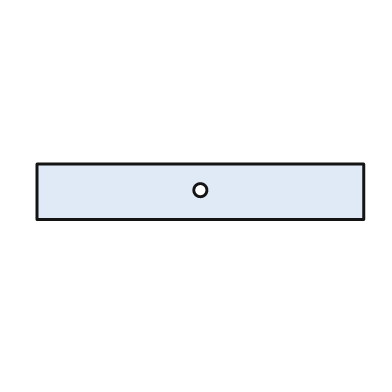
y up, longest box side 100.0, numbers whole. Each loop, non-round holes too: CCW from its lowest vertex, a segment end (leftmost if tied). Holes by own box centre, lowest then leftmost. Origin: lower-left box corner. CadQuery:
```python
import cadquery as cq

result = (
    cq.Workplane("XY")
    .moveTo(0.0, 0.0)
    .lineTo(100.0, 0.0)
    .lineTo(100.0, 17.0)
    .lineTo(0.0, 17.0)
    .close()
    .moveTo(50.0, 9.0)
    .circle(2.0)
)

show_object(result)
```